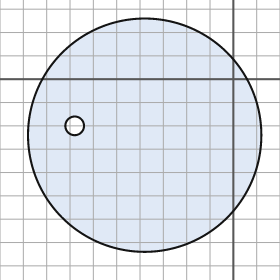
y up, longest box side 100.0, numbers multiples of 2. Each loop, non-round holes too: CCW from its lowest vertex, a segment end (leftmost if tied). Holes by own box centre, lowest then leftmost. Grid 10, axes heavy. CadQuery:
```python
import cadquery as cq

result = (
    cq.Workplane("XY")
    .moveTo(-38.0, -24.0)
    .circle(50.0)
    .moveTo(-68.0, -20.0)
    .circle(4.0)
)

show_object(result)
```